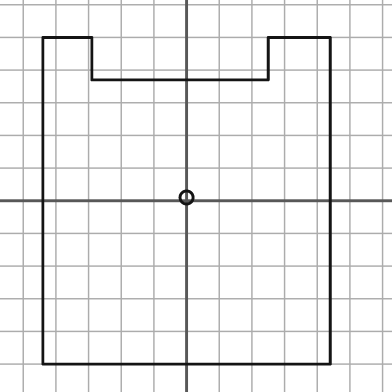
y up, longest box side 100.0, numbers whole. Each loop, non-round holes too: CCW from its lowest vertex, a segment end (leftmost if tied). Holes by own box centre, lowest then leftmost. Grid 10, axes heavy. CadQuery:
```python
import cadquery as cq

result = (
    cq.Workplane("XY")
    .moveTo(-44.0, -50.0)
    .lineTo(44.0, -50.0)
    .lineTo(44.0, 50.0)
    .lineTo(25.0, 50.0)
    .lineTo(25.0, 37.0)
    .lineTo(-29.0, 37.0)
    .lineTo(-29.0, 50.0)
    .lineTo(-44.0, 50.0)
    .close()
    .moveTo(0.0, 1.0)
    .circle(2.0)
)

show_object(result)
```